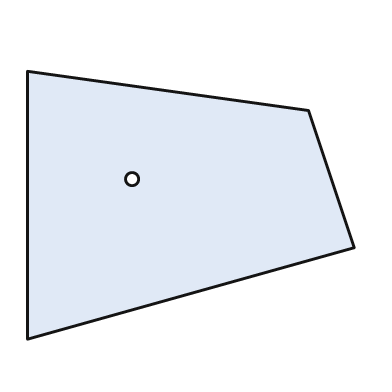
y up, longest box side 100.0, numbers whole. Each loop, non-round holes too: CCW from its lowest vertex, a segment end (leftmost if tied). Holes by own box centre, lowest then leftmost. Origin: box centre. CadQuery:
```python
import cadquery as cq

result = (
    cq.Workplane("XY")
    .moveTo(-50.0, -41.0)
    .lineTo(50.0, -13.0)
    .lineTo(36.0, 29.0)
    .lineTo(-50.0, 41.0)
    .close()
    .moveTo(-18.0, 8.0)
    .circle(2.0)
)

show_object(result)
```